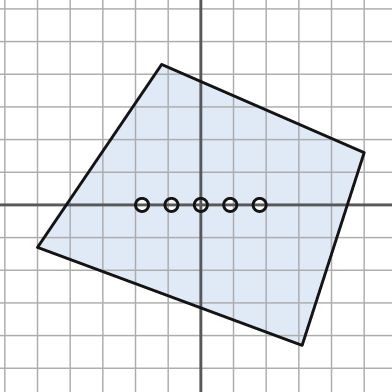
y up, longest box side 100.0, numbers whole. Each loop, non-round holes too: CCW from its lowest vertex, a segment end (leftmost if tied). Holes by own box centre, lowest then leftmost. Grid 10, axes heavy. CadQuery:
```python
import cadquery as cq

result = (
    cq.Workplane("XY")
    .moveTo(31.0, -43.0)
    .lineTo(50.0, 16.0)
    .lineTo(-12.0, 43.0)
    .lineTo(-50.0, -13.0)
    .close()
    .moveTo(-18.0, 0.0)
    .circle(2.0)
    .moveTo(-9.0, 0.0)
    .circle(2.0)
    .moveTo(0.0, 0.0)
    .circle(2.0)
    .moveTo(9.0, 0.0)
    .circle(2.0)
    .moveTo(18.0, 0.0)
    .circle(2.0)
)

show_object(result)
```